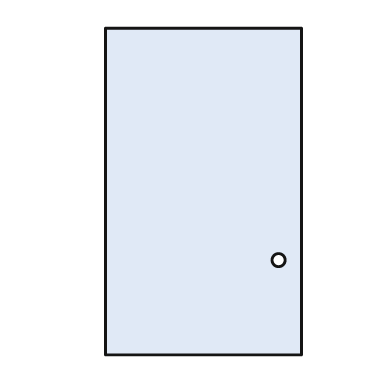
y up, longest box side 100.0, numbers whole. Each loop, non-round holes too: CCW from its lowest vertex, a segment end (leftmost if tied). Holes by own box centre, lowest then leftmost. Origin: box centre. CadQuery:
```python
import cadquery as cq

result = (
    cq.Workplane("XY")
    .moveTo(-30.0, -50.0)
    .lineTo(30.0, -50.0)
    .lineTo(30.0, 50.0)
    .lineTo(-30.0, 50.0)
    .close()
    .moveTo(23.0, -21.0)
    .circle(2.0)
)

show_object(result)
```